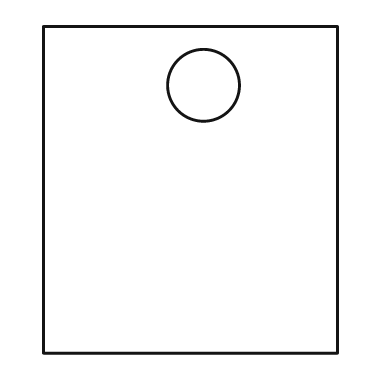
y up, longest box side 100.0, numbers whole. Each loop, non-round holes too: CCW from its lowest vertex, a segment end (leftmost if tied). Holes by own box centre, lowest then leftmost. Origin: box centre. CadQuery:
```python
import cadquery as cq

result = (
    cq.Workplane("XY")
    .moveTo(-45.0, -50.0)
    .lineTo(45.0, -50.0)
    .lineTo(45.0, 50.0)
    .lineTo(-45.0, 50.0)
    .close()
    .moveTo(4.0, 32.0)
    .circle(11.0)
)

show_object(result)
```